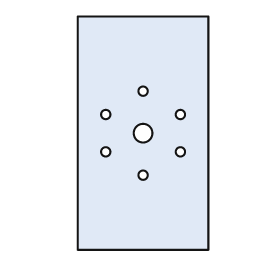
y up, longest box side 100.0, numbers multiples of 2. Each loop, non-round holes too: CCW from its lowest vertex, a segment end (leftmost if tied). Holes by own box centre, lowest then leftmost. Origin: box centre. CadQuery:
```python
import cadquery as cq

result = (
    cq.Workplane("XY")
    .moveTo(-28.0, -50.0)
    .lineTo(28.0, -50.0)
    .lineTo(28.0, 50.0)
    .lineTo(-28.0, 50.0)
    .close()
    .moveTo(0.0, -18.0)
    .circle(2.0)
    .moveTo(-16.0, -8.0)
    .circle(2.0)
    .moveTo(16.0, -8.0)
    .circle(2.0)
    .moveTo(0.0, 0.0)
    .circle(4.0)
    .moveTo(-16.0, 8.0)
    .circle(2.0)
    .moveTo(16.0, 8.0)
    .circle(2.0)
    .moveTo(0.0, 18.0)
    .circle(2.0)
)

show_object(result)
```